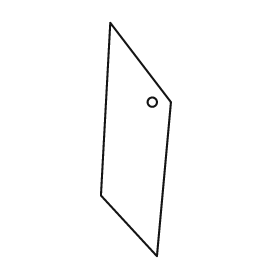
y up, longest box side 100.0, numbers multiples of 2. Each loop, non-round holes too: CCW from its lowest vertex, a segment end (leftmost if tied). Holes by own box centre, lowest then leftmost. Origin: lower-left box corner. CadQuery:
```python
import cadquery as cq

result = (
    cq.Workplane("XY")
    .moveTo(24.0, 0.0)
    .lineTo(30.0, 66.0)
    .lineTo(4.0, 100.0)
    .lineTo(0.0, 26.0)
    .close()
    .moveTo(22.0, 66.0)
    .circle(2.0)
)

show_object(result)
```